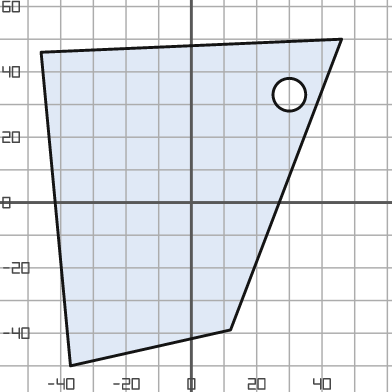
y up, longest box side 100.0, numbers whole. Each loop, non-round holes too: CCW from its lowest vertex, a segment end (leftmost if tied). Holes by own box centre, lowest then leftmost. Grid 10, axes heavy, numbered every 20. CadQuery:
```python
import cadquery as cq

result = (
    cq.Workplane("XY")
    .moveTo(-37.0, -50.0)
    .lineTo(12.0, -39.0)
    .lineTo(46.0, 50.0)
    .lineTo(-46.0, 46.0)
    .close()
    .moveTo(30.0, 33.0)
    .circle(5.0)
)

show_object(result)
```